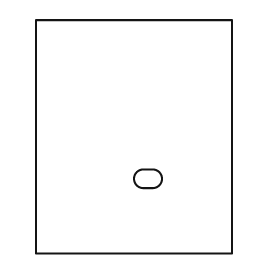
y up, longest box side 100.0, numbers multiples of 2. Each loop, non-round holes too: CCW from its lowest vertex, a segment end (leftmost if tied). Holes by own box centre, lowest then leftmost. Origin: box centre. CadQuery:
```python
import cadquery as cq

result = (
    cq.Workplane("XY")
    .moveTo(-42.0, -50.0)
    .lineTo(42.0, -50.0)
    .lineTo(42.0, 50.0)
    .lineTo(-42.0, 50.0)
    .close()
    .moveTo(4.0, -22.0)
    .lineTo(8.0, -22.0)
    .threePointArc((12.0, -18.0), (8.0, -14.0))
    .lineTo(4.0, -14.0)
    .threePointArc((0.0, -18.0), (4.0, -22.0))
    .close()
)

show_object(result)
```